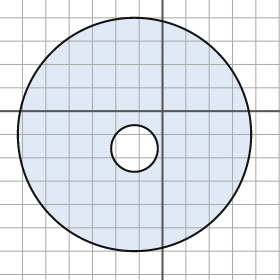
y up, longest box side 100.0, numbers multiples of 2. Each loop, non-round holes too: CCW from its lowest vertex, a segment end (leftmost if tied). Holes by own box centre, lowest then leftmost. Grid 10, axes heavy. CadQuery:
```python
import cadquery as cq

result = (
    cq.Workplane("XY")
    .moveTo(-12.0, -10.0)
    .circle(50.0)
    .moveTo(-12.0, -16.0)
    .circle(10.0)
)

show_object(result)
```